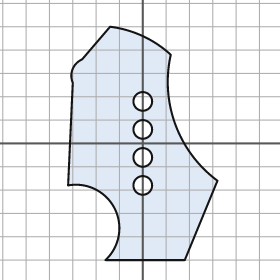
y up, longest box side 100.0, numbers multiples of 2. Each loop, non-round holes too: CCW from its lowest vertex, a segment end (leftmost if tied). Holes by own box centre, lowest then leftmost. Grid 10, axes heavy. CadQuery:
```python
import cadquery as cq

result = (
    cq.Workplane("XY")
    .moveTo(-16.0, -50.0)
    .lineTo(18.0, -50.0)
    .lineTo(32.0, -16.0)
    .threePointArc((14.0, 8.0), (12.0, 38.0))
    .threePointArc((0.0, 46.0), (-14.0, 50.0))
    .lineTo(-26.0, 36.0)
    .threePointArc((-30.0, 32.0), (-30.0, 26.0))
    .lineTo(-32.0, -18.0)
    .threePointArc((-12.0, -28.0), (-16.0, -50.0))
    .close()
    .moveTo(0.0, -18.0)
    .circle(4.0)
    .moveTo(0.0, -6.0)
    .circle(4.0)
    .moveTo(0.0, 6.0)
    .circle(4.0)
    .moveTo(0.0, 18.0)
    .circle(4.0)
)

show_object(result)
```